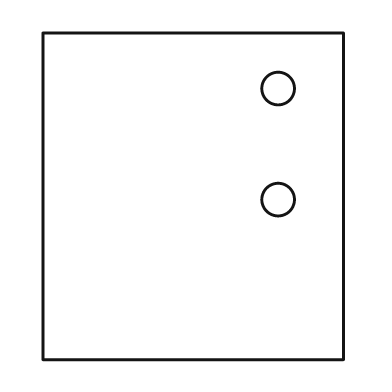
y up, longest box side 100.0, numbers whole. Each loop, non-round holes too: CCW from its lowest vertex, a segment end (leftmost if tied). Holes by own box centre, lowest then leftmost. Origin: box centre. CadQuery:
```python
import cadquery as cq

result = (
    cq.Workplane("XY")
    .moveTo(-46.0, -50.0)
    .lineTo(46.0, -50.0)
    .lineTo(46.0, 50.0)
    .lineTo(-46.0, 50.0)
    .close()
    .moveTo(26.0, -1.0)
    .circle(5.0)
    .moveTo(26.0, 33.0)
    .circle(5.0)
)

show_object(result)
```